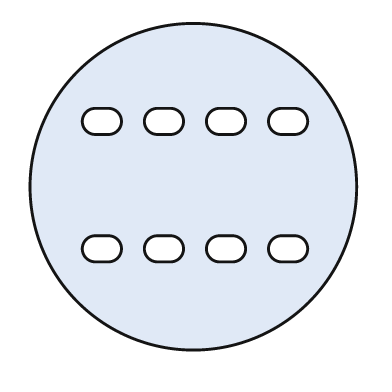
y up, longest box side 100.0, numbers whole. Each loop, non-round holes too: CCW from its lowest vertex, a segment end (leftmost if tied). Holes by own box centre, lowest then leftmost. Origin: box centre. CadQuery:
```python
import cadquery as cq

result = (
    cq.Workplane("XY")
    .moveTo(0.0, 0.0)
    .circle(50.0)
    .moveTo(-30.0, -23.0)
    .lineTo(-26.0, -23.0)
    .threePointArc((-22.0, -19.0), (-26.0, -15.0))
    .lineTo(-30.0, -15.0)
    .threePointArc((-34.0, -19.0), (-30.0, -23.0))
    .close()
    .moveTo(-11.0, -23.0)
    .lineTo(-7.0, -23.0)
    .threePointArc((-3.0, -19.0), (-7.0, -15.0))
    .lineTo(-11.0, -15.0)
    .threePointArc((-15.0, -19.0), (-11.0, -23.0))
    .close()
    .moveTo(8.0, -23.0)
    .lineTo(12.0, -23.0)
    .threePointArc((16.0, -19.0), (12.0, -15.0))
    .lineTo(8.0, -15.0)
    .threePointArc((4.0, -19.0), (8.0, -23.0))
    .close()
    .moveTo(27.0, -23.0)
    .lineTo(31.0, -23.0)
    .threePointArc((35.0, -19.0), (31.0, -15.0))
    .lineTo(27.0, -15.0)
    .threePointArc((23.0, -19.0), (27.0, -23.0))
    .close()
    .moveTo(-30.0, 16.0)
    .lineTo(-26.0, 16.0)
    .threePointArc((-22.0, 20.0), (-26.0, 24.0))
    .lineTo(-30.0, 24.0)
    .threePointArc((-34.0, 20.0), (-30.0, 16.0))
    .close()
    .moveTo(-11.0, 16.0)
    .lineTo(-7.0, 16.0)
    .threePointArc((-3.0, 20.0), (-7.0, 24.0))
    .lineTo(-11.0, 24.0)
    .threePointArc((-15.0, 20.0), (-11.0, 16.0))
    .close()
    .moveTo(8.0, 16.0)
    .lineTo(12.0, 16.0)
    .threePointArc((16.0, 20.0), (12.0, 24.0))
    .lineTo(8.0, 24.0)
    .threePointArc((4.0, 20.0), (8.0, 16.0))
    .close()
    .moveTo(27.0, 16.0)
    .lineTo(31.0, 16.0)
    .threePointArc((35.0, 20.0), (31.0, 24.0))
    .lineTo(27.0, 24.0)
    .threePointArc((23.0, 20.0), (27.0, 16.0))
    .close()
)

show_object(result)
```